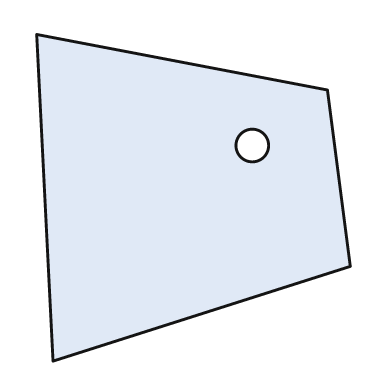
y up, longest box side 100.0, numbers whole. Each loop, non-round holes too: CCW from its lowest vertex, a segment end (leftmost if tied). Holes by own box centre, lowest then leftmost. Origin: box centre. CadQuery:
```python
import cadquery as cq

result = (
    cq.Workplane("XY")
    .moveTo(-43.0, -50.0)
    .lineTo(48.0, -21.0)
    .lineTo(41.0, 33.0)
    .lineTo(-48.0, 50.0)
    .close()
    .moveTo(18.0, 16.0)
    .circle(5.0)
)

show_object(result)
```